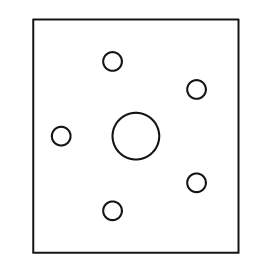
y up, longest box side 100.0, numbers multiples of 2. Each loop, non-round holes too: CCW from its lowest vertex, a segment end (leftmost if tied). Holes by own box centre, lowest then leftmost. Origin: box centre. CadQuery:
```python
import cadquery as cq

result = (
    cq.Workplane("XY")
    .moveTo(-44.0, -50.0)
    .lineTo(44.0, -50.0)
    .lineTo(44.0, 50.0)
    .lineTo(-44.0, 50.0)
    .close()
    .moveTo(-10.0, -32.0)
    .circle(4.0)
    .moveTo(26.0, -20.0)
    .circle(4.0)
    .moveTo(-32.0, 0.0)
    .circle(4.0)
    .moveTo(0.0, 0.0)
    .circle(10.0)
    .moveTo(26.0, 20.0)
    .circle(4.0)
    .moveTo(-10.0, 32.0)
    .circle(4.0)
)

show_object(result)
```